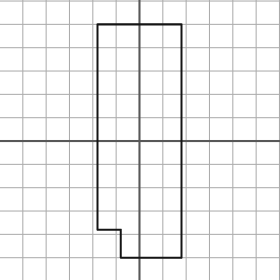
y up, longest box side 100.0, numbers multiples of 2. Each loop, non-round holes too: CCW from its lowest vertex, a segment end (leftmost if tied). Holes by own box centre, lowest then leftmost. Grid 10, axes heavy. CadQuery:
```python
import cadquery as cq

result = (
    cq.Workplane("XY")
    .moveTo(-8.0, -50.0)
    .lineTo(18.0, -50.0)
    .lineTo(18.0, 50.0)
    .lineTo(-18.0, 50.0)
    .lineTo(-18.0, -38.0)
    .lineTo(-8.0, -38.0)
    .close()
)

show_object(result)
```